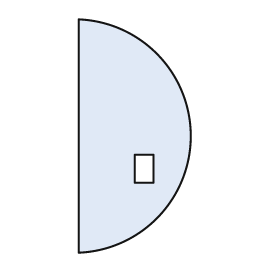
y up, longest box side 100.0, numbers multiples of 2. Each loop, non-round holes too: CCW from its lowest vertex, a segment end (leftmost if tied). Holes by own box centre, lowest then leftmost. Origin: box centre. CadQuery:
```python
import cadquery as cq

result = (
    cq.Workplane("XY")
    .moveTo(-24.0, -50.0)
    .threePointArc((24.0, 0.0), (-24.0, 50.0))
    .close()
    .moveTo(0.0, -20.0)
    .lineTo(8.0, -20.0)
    .lineTo(8.0, -8.0)
    .lineTo(0.0, -8.0)
    .close()
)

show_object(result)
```